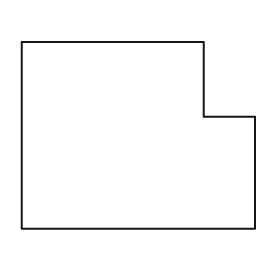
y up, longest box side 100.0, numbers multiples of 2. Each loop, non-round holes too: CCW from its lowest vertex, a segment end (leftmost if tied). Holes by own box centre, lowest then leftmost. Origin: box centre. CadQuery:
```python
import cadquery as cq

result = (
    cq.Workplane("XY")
    .moveTo(-50.0, -40.0)
    .lineTo(50.0, -40.0)
    .lineTo(50.0, 8.0)
    .lineTo(28.0, 8.0)
    .lineTo(28.0, 40.0)
    .lineTo(-50.0, 40.0)
    .close()
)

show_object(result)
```